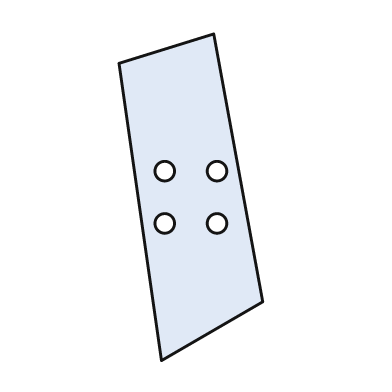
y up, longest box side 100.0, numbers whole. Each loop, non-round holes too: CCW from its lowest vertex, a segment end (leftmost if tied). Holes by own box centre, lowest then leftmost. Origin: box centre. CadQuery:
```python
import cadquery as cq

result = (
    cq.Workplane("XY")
    .moveTo(-9.0, -50.0)
    .lineTo(22.0, -32.0)
    .lineTo(7.0, 50.0)
    .lineTo(-22.0, 41.0)
    .close()
    .moveTo(-8.0, -8.0)
    .circle(3.0)
    .moveTo(8.0, -8.0)
    .circle(3.0)
    .moveTo(-8.0, 8.0)
    .circle(3.0)
    .moveTo(8.0, 8.0)
    .circle(3.0)
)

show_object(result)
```